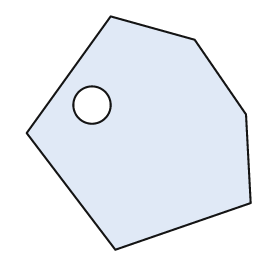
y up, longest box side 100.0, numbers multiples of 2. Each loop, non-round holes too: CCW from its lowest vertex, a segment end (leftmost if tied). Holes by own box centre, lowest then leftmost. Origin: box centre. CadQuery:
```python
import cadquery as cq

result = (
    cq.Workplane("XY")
    .moveTo(-10.0, -50.0)
    .lineTo(48.0, -30.0)
    .lineTo(46.0, 8.0)
    .lineTo(24.0, 40.0)
    .lineTo(-12.0, 50.0)
    .lineTo(-48.0, 0.0)
    .close()
    .moveTo(-20.0, 12.0)
    .circle(8.0)
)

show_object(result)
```